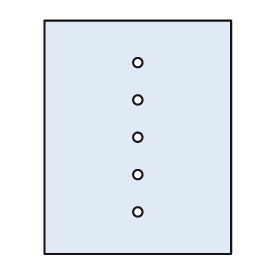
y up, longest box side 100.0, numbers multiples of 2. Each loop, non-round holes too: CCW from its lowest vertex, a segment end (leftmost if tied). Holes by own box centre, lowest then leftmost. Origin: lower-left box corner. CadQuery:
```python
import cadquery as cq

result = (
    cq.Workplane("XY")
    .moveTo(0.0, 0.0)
    .lineTo(80.0, 0.0)
    .lineTo(80.0, 100.0)
    .lineTo(0.0, 100.0)
    .close()
    .moveTo(40.0, 18.0)
    .circle(2.0)
    .moveTo(40.0, 34.0)
    .circle(2.0)
    .moveTo(40.0, 50.0)
    .circle(2.0)
    .moveTo(40.0, 66.0)
    .circle(2.0)
    .moveTo(40.0, 82.0)
    .circle(2.0)
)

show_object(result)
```